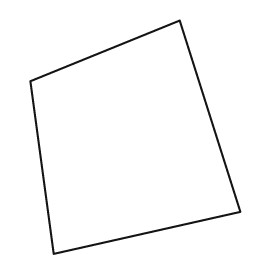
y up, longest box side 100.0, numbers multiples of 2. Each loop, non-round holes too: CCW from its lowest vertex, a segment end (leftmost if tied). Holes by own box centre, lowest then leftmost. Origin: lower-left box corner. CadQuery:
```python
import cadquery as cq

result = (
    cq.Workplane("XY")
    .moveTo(10.0, 0.0)
    .lineTo(90.0, 18.0)
    .lineTo(64.0, 100.0)
    .lineTo(0.0, 74.0)
    .close()
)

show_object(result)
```